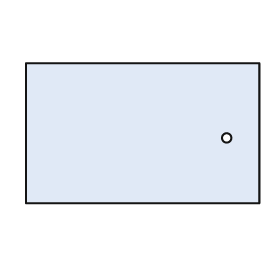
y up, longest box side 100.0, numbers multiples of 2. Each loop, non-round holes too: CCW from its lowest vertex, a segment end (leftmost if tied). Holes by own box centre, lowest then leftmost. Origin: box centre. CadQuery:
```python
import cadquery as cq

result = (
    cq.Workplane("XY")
    .moveTo(-50.0, -30.0)
    .lineTo(50.0, -30.0)
    .lineTo(50.0, 30.0)
    .lineTo(-50.0, 30.0)
    .close()
    .moveTo(36.0, -2.0)
    .circle(2.0)
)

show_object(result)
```